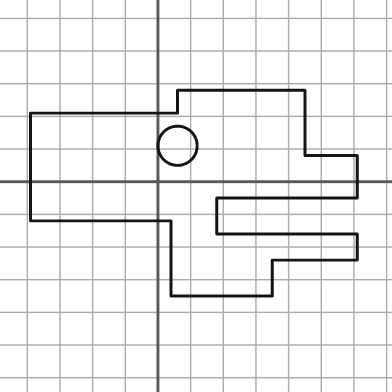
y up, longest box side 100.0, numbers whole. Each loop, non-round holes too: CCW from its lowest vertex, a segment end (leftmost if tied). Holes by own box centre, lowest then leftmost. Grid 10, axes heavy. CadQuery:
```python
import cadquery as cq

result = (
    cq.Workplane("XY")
    .moveTo(4.0, -35.0)
    .lineTo(35.0, -35.0)
    .lineTo(35.0, -24.0)
    .lineTo(61.0, -24.0)
    .lineTo(61.0, -16.0)
    .lineTo(18.0, -16.0)
    .lineTo(18.0, -5.0)
    .lineTo(61.0, -5.0)
    .lineTo(61.0, 8.0)
    .lineTo(45.0, 8.0)
    .lineTo(45.0, 28.0)
    .lineTo(6.0, 28.0)
    .lineTo(6.0, 21.0)
    .lineTo(-39.0, 21.0)
    .lineTo(-39.0, -12.0)
    .lineTo(4.0, -12.0)
    .close()
    .moveTo(6.0, 11.0)
    .circle(6.0)
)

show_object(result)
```